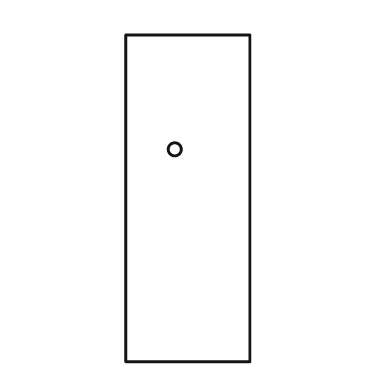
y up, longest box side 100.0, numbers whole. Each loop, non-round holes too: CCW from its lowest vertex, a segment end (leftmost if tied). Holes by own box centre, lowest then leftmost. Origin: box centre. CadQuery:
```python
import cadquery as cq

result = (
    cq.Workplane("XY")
    .moveTo(-19.0, -50.0)
    .lineTo(19.0, -50.0)
    .lineTo(19.0, 50.0)
    .lineTo(-19.0, 50.0)
    .close()
    .moveTo(-4.0, 15.0)
    .circle(2.0)
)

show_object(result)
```